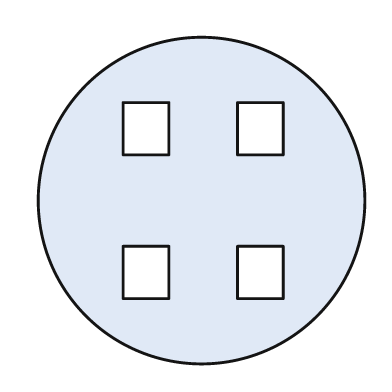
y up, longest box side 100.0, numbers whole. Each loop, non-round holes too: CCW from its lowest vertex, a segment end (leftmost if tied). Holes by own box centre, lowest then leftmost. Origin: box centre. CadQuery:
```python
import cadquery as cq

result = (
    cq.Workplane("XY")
    .moveTo(0.0, 0.0)
    .circle(50.0)
    .moveTo(-24.0, -30.0)
    .lineTo(-10.0, -30.0)
    .lineTo(-10.0, -14.0)
    .lineTo(-24.0, -14.0)
    .close()
    .moveTo(11.0, -30.0)
    .lineTo(25.0, -30.0)
    .lineTo(25.0, -14.0)
    .lineTo(11.0, -14.0)
    .close()
    .moveTo(-24.0, 14.0)
    .lineTo(-10.0, 14.0)
    .lineTo(-10.0, 30.0)
    .lineTo(-24.0, 30.0)
    .close()
    .moveTo(11.0, 14.0)
    .lineTo(25.0, 14.0)
    .lineTo(25.0, 30.0)
    .lineTo(11.0, 30.0)
    .close()
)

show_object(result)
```